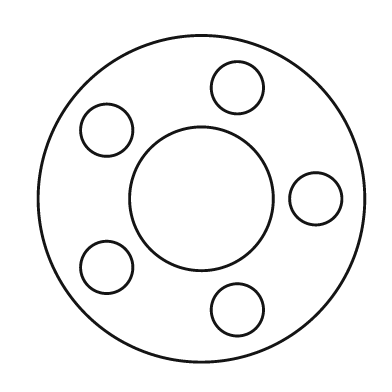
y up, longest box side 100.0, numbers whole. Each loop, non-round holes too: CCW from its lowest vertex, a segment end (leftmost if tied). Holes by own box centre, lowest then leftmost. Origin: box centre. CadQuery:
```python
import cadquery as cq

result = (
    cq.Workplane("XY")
    .moveTo(0.0, 0.0)
    .circle(50.0)
    .moveTo(11.0, -34.0)
    .circle(8.0)
    .moveTo(-29.0, -21.0)
    .circle(8.0)
    .moveTo(0.0, 0.0)
    .circle(22.0)
    .moveTo(35.0, 0.0)
    .circle(8.0)
    .moveTo(-29.0, 21.0)
    .circle(8.0)
    .moveTo(11.0, 34.0)
    .circle(8.0)
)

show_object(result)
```